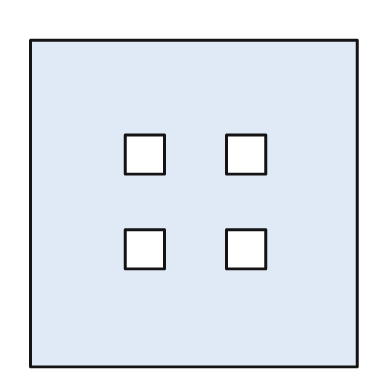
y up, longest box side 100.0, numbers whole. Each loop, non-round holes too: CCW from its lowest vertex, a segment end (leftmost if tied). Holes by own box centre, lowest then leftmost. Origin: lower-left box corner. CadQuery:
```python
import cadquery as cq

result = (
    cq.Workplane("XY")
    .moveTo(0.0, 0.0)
    .lineTo(100.0, 0.0)
    .lineTo(100.0, 100.0)
    .lineTo(0.0, 100.0)
    .close()
    .moveTo(29.0, 30.0)
    .lineTo(41.0, 30.0)
    .lineTo(41.0, 42.0)
    .lineTo(29.0, 42.0)
    .close()
    .moveTo(60.0, 30.0)
    .lineTo(72.0, 30.0)
    .lineTo(72.0, 42.0)
    .lineTo(60.0, 42.0)
    .close()
    .moveTo(29.0, 59.0)
    .lineTo(41.0, 59.0)
    .lineTo(41.0, 71.0)
    .lineTo(29.0, 71.0)
    .close()
    .moveTo(60.0, 59.0)
    .lineTo(72.0, 59.0)
    .lineTo(72.0, 71.0)
    .lineTo(60.0, 71.0)
    .close()
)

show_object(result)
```